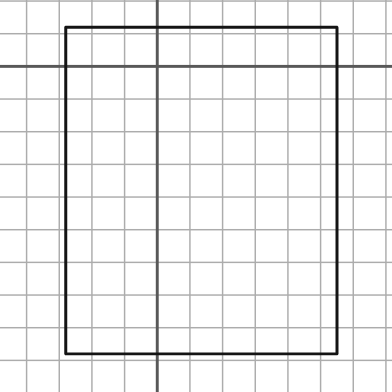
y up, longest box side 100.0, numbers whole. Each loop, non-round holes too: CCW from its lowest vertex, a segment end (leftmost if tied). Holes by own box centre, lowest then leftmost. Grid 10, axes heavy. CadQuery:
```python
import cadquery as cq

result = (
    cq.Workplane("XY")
    .moveTo(-28.0, -88.0)
    .lineTo(55.0, -88.0)
    .lineTo(55.0, 12.0)
    .lineTo(-28.0, 12.0)
    .close()
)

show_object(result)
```